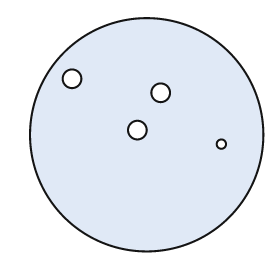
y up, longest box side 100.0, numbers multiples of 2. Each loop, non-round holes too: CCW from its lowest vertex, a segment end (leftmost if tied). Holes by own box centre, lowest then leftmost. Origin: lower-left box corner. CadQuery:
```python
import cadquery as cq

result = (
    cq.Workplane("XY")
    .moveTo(50.0, 50.0)
    .circle(50.0)
    .moveTo(82.0, 46.0)
    .circle(2.0)
    .moveTo(46.0, 52.0)
    .circle(4.0)
    .moveTo(56.0, 68.0)
    .circle(4.0)
    .moveTo(18.0, 74.0)
    .circle(4.0)
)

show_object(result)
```